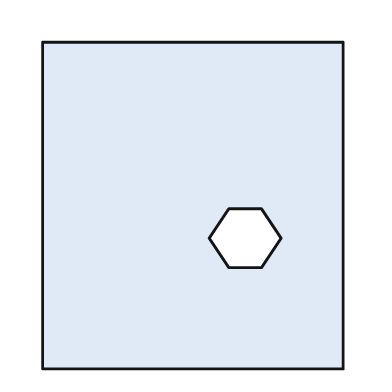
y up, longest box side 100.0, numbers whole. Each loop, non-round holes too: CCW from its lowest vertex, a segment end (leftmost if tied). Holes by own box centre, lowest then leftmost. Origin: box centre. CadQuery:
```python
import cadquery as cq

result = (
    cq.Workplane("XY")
    .moveTo(-46.0, -50.0)
    .lineTo(46.0, -50.0)
    .lineTo(46.0, 50.0)
    .lineTo(-46.0, 50.0)
    .close()
    .moveTo(11.0, -19.0)
    .lineTo(21.0, -19.0)
    .lineTo(27.0, -10.0)
    .lineTo(21.0, -1.0)
    .lineTo(11.0, -1.0)
    .lineTo(5.0, -10.0)
    .close()
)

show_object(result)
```